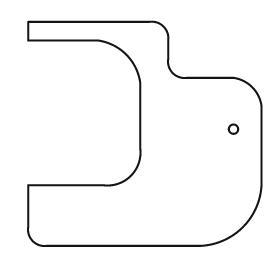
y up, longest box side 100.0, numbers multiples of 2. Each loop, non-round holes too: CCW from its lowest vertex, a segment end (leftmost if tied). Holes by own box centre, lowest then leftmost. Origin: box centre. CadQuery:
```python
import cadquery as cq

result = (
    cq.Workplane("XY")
    .moveTo(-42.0, -48.0)
    .lineTo(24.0, -48.0)
    .threePointArc((42.0, -40.0), (50.0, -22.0))
    .lineTo(50.0, 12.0)
    .threePointArc((46.0, 20.0), (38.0, 24.0))
    .lineTo(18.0, 24.0)
    .threePointArc((12.0, 26.0), (10.0, 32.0))
    .lineTo(10.0, 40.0)
    .threePointArc((8.0, 46.0), (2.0, 48.0))
    .lineTo(-50.0, 48.0)
    .lineTo(-50.0, 40.0)
    .lineTo(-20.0, 40.0)
    .threePointArc((-8.0, 34.0), (-2.0, 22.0))
    .lineTo(-2.0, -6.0)
    .threePointArc((-6.0, -18.0), (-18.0, -22.0))
    .lineTo(-50.0, -22.0)
    .lineTo(-50.0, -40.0)
    .threePointArc((-48.0, -46.0), (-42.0, -48.0))
    .close()
    .moveTo(38.0, 2.0)
    .circle(2.0)
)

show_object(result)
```